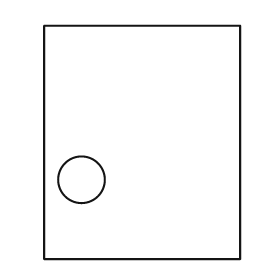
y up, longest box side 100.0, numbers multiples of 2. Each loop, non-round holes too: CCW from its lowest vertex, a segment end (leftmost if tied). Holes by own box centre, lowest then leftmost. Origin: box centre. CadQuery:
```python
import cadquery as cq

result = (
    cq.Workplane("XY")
    .moveTo(-42.0, -50.0)
    .lineTo(42.0, -50.0)
    .lineTo(42.0, 50.0)
    .lineTo(-42.0, 50.0)
    .close()
    .moveTo(-26.0, -16.0)
    .circle(10.0)
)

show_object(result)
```